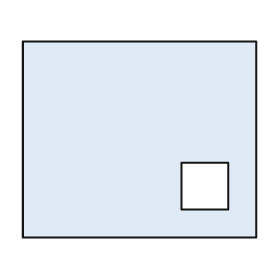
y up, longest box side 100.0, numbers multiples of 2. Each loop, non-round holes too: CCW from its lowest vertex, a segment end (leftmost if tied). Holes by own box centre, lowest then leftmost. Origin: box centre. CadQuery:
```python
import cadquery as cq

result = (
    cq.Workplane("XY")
    .moveTo(-50.0, -42.0)
    .lineTo(50.0, -42.0)
    .lineTo(50.0, 42.0)
    .lineTo(-50.0, 42.0)
    .close()
    .moveTo(18.0, -30.0)
    .lineTo(38.0, -30.0)
    .lineTo(38.0, -10.0)
    .lineTo(18.0, -10.0)
    .close()
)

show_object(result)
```